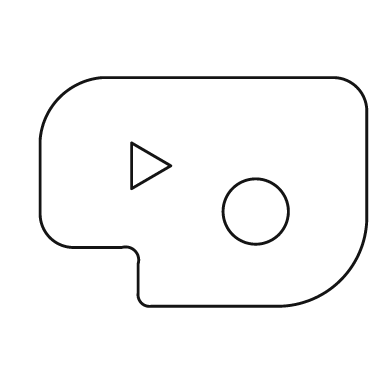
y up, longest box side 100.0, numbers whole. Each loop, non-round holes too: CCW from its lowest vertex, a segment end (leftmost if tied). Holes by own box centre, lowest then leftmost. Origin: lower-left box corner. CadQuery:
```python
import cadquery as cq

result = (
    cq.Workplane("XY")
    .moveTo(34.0, 0.0)
    .lineTo(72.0, 0.0)
    .threePointArc((92.0, 8.0), (100.0, 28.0))
    .lineTo(100.0, 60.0)
    .threePointArc((97.0, 67.0), (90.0, 70.0))
    .lineTo(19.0, 70.0)
    .threePointArc((6.0, 64.0), (0.0, 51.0))
    .lineTo(0.0, 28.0)
    .threePointArc((3.0, 21.0), (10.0, 18.0))
    .lineTo(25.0, 18.0)
    .threePointArc((29.0, 17.0), (30.0, 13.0))
    .lineTo(30.0, 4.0)
    .threePointArc((31.0, 1.0), (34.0, 0.0))
    .close()
    .moveTo(66.0, 29.0)
    .circle(10.0)
    .moveTo(28.0, 36.0)
    .lineTo(40.0, 43.0)
    .lineTo(28.0, 50.0)
    .close()
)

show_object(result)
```